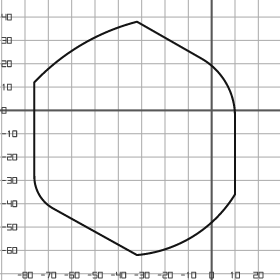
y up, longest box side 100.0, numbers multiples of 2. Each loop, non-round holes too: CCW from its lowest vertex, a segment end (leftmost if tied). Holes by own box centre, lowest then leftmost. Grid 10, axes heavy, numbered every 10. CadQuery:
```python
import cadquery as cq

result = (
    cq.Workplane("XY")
    .moveTo(-32.0, -62.0)
    .threePointArc((-8.0, -54.0), (10.0, -36.0))
    .lineTo(10.0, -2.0)
    .threePointArc((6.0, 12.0), (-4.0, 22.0))
    .lineTo(-32.0, 38.0)
    .threePointArc((-56.0, 28.0), (-76.0, 12.0))
    .lineTo(-76.0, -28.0)
    .threePointArc((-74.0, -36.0), (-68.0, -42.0))
    .close()
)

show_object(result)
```